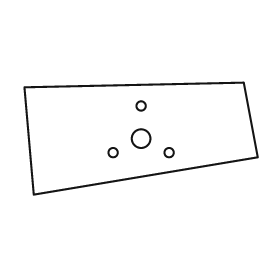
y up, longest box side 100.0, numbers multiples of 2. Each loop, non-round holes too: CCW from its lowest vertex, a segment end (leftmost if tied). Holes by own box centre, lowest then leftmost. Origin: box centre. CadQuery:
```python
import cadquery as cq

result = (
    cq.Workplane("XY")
    .moveTo(-46.0, -24.0)
    .lineTo(50.0, -8.0)
    .lineTo(44.0, 24.0)
    .lineTo(-50.0, 22.0)
    .close()
    .moveTo(-12.0, -6.0)
    .circle(2.0)
    .moveTo(12.0, -6.0)
    .circle(2.0)
    .moveTo(0.0, 0.0)
    .circle(4.0)
    .moveTo(0.0, 14.0)
    .circle(2.0)
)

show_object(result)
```